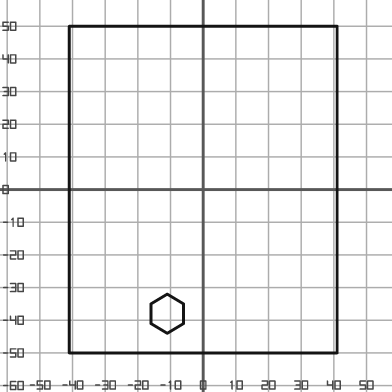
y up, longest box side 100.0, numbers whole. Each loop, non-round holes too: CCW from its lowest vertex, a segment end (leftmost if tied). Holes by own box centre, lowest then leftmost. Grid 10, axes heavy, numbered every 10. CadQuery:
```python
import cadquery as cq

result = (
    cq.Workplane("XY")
    .moveTo(-41.0, -50.0)
    .lineTo(41.0, -50.0)
    .lineTo(41.0, 50.0)
    .lineTo(-41.0, 50.0)
    .close()
    .moveTo(-11.0, -44.0)
    .lineTo(-6.0, -41.0)
    .lineTo(-6.0, -35.0)
    .lineTo(-11.0, -32.0)
    .lineTo(-16.0, -35.0)
    .lineTo(-16.0, -41.0)
    .close()
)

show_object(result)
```